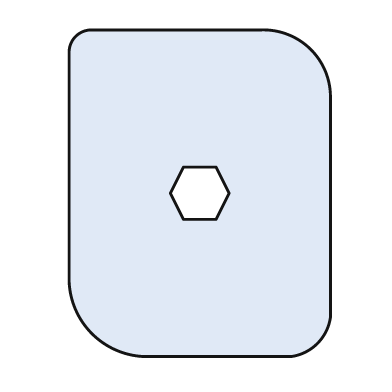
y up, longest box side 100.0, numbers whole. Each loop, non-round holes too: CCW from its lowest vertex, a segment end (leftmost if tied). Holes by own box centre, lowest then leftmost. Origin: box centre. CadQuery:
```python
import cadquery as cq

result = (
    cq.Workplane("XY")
    .moveTo(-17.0, -50.0)
    .lineTo(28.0, -50.0)
    .threePointArc((36.0, -46.0), (40.0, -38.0))
    .lineTo(40.0, 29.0)
    .threePointArc((34.0, 44.0), (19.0, 50.0))
    .lineTo(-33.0, 50.0)
    .threePointArc((-38.0, 48.0), (-40.0, 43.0))
    .lineTo(-40.0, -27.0)
    .threePointArc((-33.0, -43.0), (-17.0, -50.0))
    .close()
    .moveTo(-5.0, -8.0)
    .lineTo(5.0, -8.0)
    .lineTo(9.0, 0.0)
    .lineTo(5.0, 8.0)
    .lineTo(-5.0, 8.0)
    .lineTo(-9.0, 0.0)
    .close()
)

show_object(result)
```